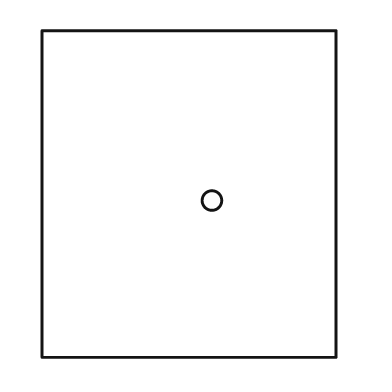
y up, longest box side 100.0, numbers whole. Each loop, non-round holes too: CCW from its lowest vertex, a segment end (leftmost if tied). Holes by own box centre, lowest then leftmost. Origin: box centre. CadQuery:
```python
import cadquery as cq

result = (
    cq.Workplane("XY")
    .moveTo(-45.0, -50.0)
    .lineTo(45.0, -50.0)
    .lineTo(45.0, 50.0)
    .lineTo(-45.0, 50.0)
    .close()
    .moveTo(7.0, -2.0)
    .circle(3.0)
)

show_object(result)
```